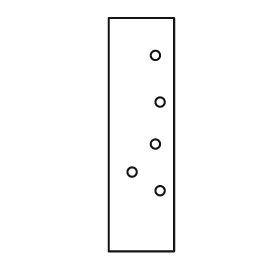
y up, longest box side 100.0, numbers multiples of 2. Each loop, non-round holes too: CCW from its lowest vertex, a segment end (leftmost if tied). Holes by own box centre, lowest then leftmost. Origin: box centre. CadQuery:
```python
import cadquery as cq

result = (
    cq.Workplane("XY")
    .moveTo(-14.0, -50.0)
    .lineTo(14.0, -50.0)
    .lineTo(14.0, 50.0)
    .lineTo(-14.0, 50.0)
    .close()
    .moveTo(8.0, -24.0)
    .circle(2.0)
    .moveTo(-4.0, -16.0)
    .circle(2.0)
    .moveTo(6.0, -4.0)
    .circle(2.0)
    .moveTo(8.0, 14.0)
    .circle(2.0)
    .moveTo(6.0, 34.0)
    .circle(2.0)
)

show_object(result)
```